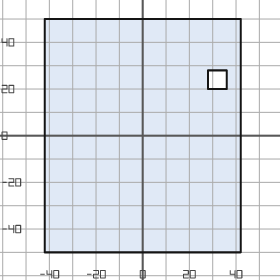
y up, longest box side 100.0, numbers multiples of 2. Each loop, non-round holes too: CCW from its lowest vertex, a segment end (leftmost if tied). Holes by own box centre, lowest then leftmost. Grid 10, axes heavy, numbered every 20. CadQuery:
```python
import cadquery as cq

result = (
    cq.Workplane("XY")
    .moveTo(-42.0, -50.0)
    .lineTo(42.0, -50.0)
    .lineTo(42.0, 50.0)
    .lineTo(-42.0, 50.0)
    .close()
    .moveTo(28.0, 20.0)
    .lineTo(36.0, 20.0)
    .lineTo(36.0, 28.0)
    .lineTo(28.0, 28.0)
    .close()
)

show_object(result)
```